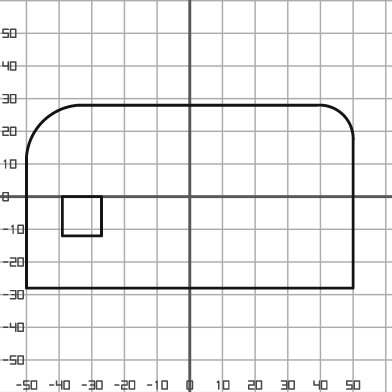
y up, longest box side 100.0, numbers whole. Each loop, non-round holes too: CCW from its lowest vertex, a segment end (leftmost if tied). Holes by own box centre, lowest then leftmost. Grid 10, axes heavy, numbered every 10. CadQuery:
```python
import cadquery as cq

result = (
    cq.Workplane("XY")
    .moveTo(-50.0, -28.0)
    .lineTo(50.0, -28.0)
    .lineTo(50.0, 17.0)
    .threePointArc((47.0, 25.0), (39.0, 28.0))
    .lineTo(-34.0, 28.0)
    .threePointArc((-45.0, 23.0), (-50.0, 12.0))
    .close()
    .moveTo(-39.0, -12.0)
    .lineTo(-27.0, -12.0)
    .lineTo(-27.0, 0.0)
    .lineTo(-39.0, 0.0)
    .close()
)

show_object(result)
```